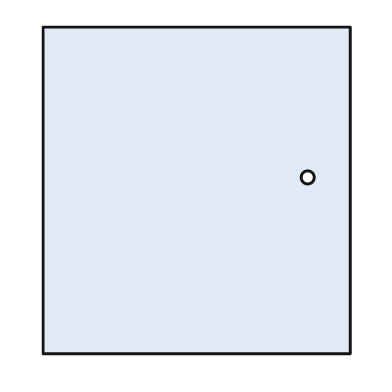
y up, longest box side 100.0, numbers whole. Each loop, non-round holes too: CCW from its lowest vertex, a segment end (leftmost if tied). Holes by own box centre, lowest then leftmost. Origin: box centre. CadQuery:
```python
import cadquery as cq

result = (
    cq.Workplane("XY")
    .moveTo(-47.0, -50.0)
    .lineTo(47.0, -50.0)
    .lineTo(47.0, 50.0)
    .lineTo(-47.0, 50.0)
    .close()
    .moveTo(34.0, 4.0)
    .circle(2.0)
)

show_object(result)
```